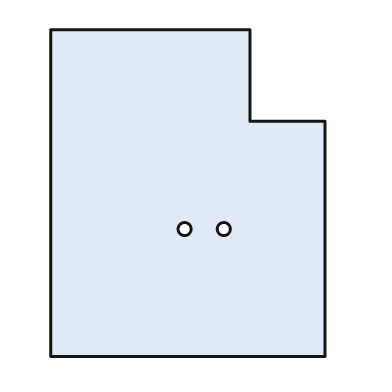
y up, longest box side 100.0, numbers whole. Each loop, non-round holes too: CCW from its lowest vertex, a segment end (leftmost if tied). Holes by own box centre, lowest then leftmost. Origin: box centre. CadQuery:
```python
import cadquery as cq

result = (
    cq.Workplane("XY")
    .moveTo(-42.0, -50.0)
    .lineTo(42.0, -50.0)
    .lineTo(42.0, 22.0)
    .lineTo(19.0, 22.0)
    .lineTo(19.0, 50.0)
    .lineTo(-42.0, 50.0)
    .close()
    .moveTo(-1.0, -11.0)
    .circle(2.0)
    .moveTo(11.0, -11.0)
    .circle(2.0)
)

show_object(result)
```